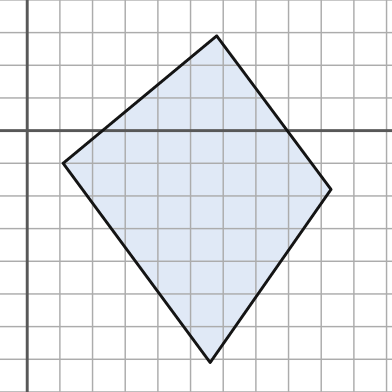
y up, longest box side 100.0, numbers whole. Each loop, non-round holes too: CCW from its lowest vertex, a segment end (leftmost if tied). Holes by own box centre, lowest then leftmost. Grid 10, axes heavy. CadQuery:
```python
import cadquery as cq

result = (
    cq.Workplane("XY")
    .moveTo(56.0, -71.0)
    .lineTo(93.0, -18.0)
    .lineTo(58.0, 29.0)
    .lineTo(11.0, -10.0)
    .close()
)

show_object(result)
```